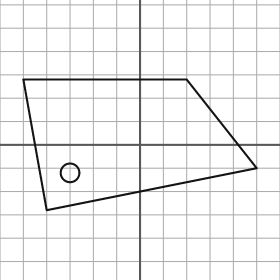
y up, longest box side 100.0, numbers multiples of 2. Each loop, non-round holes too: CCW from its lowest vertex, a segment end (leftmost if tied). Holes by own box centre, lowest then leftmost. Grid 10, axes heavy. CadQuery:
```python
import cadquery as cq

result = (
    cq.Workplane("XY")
    .moveTo(-40.0, -28.0)
    .lineTo(50.0, -10.0)
    .lineTo(20.0, 28.0)
    .lineTo(-50.0, 28.0)
    .close()
    .moveTo(-30.0, -12.0)
    .circle(4.0)
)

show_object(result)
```